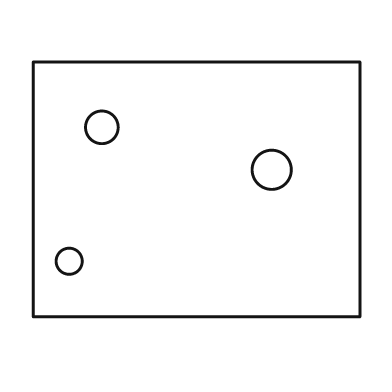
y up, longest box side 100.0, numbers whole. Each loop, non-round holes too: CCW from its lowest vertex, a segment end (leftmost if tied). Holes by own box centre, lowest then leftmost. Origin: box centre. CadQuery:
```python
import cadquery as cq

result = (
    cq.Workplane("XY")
    .moveTo(-50.0, -39.0)
    .lineTo(50.0, -39.0)
    .lineTo(50.0, 39.0)
    .lineTo(-50.0, 39.0)
    .close()
    .moveTo(-39.0, -22.0)
    .circle(4.0)
    .moveTo(23.0, 6.0)
    .circle(6.0)
    .moveTo(-29.0, 19.0)
    .circle(5.0)
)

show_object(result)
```